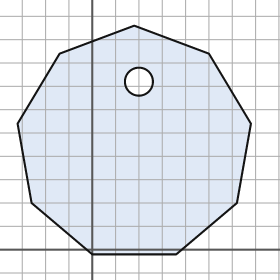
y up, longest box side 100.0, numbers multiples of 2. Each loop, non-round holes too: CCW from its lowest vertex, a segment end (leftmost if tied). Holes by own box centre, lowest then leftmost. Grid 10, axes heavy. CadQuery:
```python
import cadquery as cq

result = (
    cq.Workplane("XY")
    .moveTo(0.0, -2.0)
    .lineTo(36.0, -2.0)
    .lineTo(62.0, 20.0)
    .lineTo(68.0, 54.0)
    .lineTo(50.0, 84.0)
    .lineTo(18.0, 96.0)
    .lineTo(-14.0, 84.0)
    .lineTo(-32.0, 54.0)
    .lineTo(-26.0, 20.0)
    .close()
    .moveTo(20.0, 72.0)
    .circle(6.0)
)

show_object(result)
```